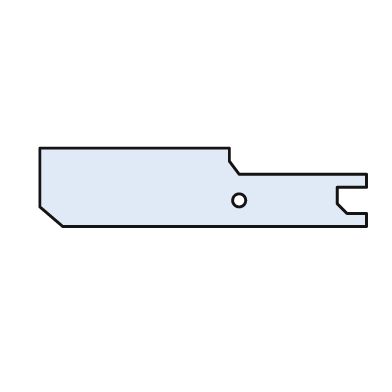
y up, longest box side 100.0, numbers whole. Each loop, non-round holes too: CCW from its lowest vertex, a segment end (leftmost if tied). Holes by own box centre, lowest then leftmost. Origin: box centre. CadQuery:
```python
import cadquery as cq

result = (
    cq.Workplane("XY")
    .moveTo(-43.0, -12.0)
    .lineTo(50.0, -12.0)
    .lineTo(50.0, -8.0)
    .lineTo(44.0, -8.0)
    .lineTo(41.0, -5.0)
    .lineTo(41.0, 0.0)
    .lineTo(50.0, 0.0)
    .lineTo(50.0, 4.0)
    .lineTo(11.0, 4.0)
    .lineTo(8.0, 8.0)
    .lineTo(8.0, 12.0)
    .lineTo(-50.0, 12.0)
    .lineTo(-50.0, -6.0)
    .close()
    .moveTo(11.0, -4.0)
    .circle(2.0)
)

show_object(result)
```